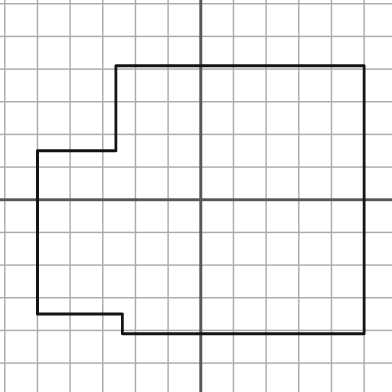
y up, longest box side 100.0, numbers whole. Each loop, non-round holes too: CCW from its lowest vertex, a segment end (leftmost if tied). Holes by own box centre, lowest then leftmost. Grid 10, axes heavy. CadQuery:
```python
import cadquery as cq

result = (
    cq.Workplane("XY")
    .moveTo(-24.0, -41.0)
    .lineTo(50.0, -41.0)
    .lineTo(50.0, 41.0)
    .lineTo(-26.0, 41.0)
    .lineTo(-26.0, 15.0)
    .lineTo(-50.0, 15.0)
    .lineTo(-50.0, -35.0)
    .lineTo(-24.0, -35.0)
    .close()
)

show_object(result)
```